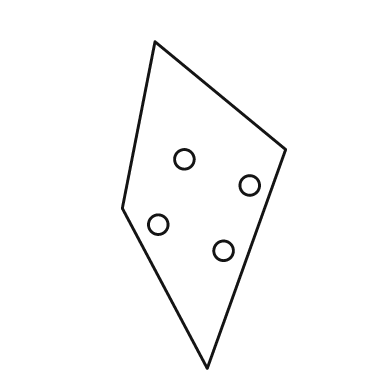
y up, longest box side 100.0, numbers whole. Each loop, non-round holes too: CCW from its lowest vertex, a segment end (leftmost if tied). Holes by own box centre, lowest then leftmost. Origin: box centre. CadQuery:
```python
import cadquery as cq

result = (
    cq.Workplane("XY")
    .moveTo(1.0, -50.0)
    .lineTo(25.0, 17.0)
    .lineTo(-15.0, 50.0)
    .lineTo(-25.0, -1.0)
    .close()
    .moveTo(6.0, -14.0)
    .circle(3.0)
    .moveTo(-14.0, -6.0)
    .circle(3.0)
    .moveTo(14.0, 6.0)
    .circle(3.0)
    .moveTo(-6.0, 14.0)
    .circle(3.0)
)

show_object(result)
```